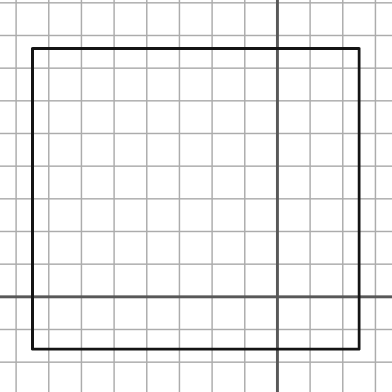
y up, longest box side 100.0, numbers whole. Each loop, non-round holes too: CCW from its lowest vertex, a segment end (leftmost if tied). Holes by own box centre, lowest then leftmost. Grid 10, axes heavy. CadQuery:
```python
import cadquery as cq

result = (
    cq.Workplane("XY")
    .moveTo(-75.0, -16.0)
    .lineTo(25.0, -16.0)
    .lineTo(25.0, 76.0)
    .lineTo(-75.0, 76.0)
    .close()
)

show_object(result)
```